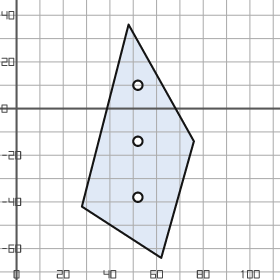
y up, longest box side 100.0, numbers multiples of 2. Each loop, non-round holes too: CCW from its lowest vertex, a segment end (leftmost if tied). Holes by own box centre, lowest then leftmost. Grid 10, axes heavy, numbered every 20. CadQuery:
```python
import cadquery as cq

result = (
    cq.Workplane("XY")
    .moveTo(62.0, -64.0)
    .lineTo(76.0, -14.0)
    .lineTo(48.0, 36.0)
    .lineTo(28.0, -42.0)
    .close()
    .moveTo(52.0, -38.0)
    .circle(2.0)
    .moveTo(52.0, -14.0)
    .circle(2.0)
    .moveTo(52.0, 10.0)
    .circle(2.0)
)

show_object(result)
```